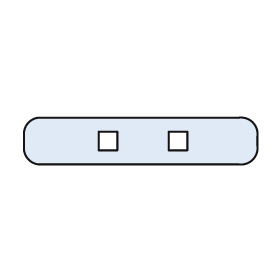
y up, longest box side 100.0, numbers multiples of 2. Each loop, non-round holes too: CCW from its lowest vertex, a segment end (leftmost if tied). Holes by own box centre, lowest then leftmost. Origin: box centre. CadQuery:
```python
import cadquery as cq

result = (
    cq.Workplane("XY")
    .moveTo(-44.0, -10.0)
    .lineTo(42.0, -10.0)
    .threePointArc((48.0, -8.0), (50.0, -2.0))
    .lineTo(50.0, 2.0)
    .threePointArc((48.0, 8.0), (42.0, 10.0))
    .lineTo(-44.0, 10.0)
    .threePointArc((-48.0, 8.0), (-50.0, 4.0))
    .lineTo(-50.0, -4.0)
    .threePointArc((-48.0, -8.0), (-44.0, -10.0))
    .close()
    .moveTo(-18.0, -4.0)
    .lineTo(-10.0, -4.0)
    .lineTo(-10.0, 4.0)
    .lineTo(-18.0, 4.0)
    .close()
    .moveTo(12.0, -4.0)
    .lineTo(20.0, -4.0)
    .lineTo(20.0, 4.0)
    .lineTo(12.0, 4.0)
    .close()
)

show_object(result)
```